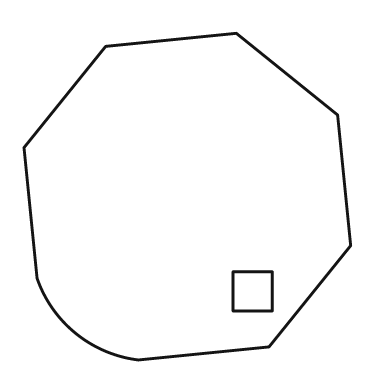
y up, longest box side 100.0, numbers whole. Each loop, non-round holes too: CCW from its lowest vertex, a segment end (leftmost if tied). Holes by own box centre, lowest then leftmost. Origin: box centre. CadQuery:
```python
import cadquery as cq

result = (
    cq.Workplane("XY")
    .moveTo(-15.0, -50.0)
    .lineTo(25.0, -46.0)
    .lineTo(50.0, -15.0)
    .lineTo(46.0, 25.0)
    .lineTo(15.0, 50.0)
    .lineTo(-25.0, 46.0)
    .lineTo(-50.0, 15.0)
    .lineTo(-46.0, -25.0)
    .threePointArc((-34.0, -42.0), (-15.0, -50.0))
    .close()
    .moveTo(14.0, -35.0)
    .lineTo(26.0, -35.0)
    .lineTo(26.0, -23.0)
    .lineTo(14.0, -23.0)
    .close()
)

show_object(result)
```